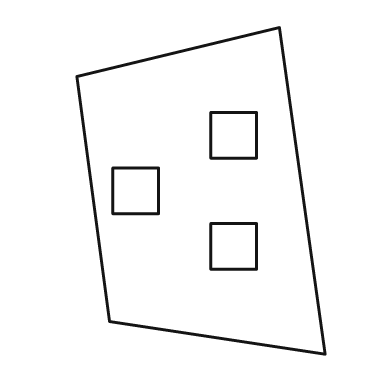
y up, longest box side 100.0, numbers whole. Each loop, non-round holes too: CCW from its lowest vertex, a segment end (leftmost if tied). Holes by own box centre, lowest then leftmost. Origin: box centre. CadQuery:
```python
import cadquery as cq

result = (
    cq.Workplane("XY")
    .moveTo(38.0, -50.0)
    .lineTo(24.0, 50.0)
    .lineTo(-38.0, 35.0)
    .lineTo(-28.0, -40.0)
    .close()
    .moveTo(3.0, -24.0)
    .lineTo(17.0, -24.0)
    .lineTo(17.0, -10.0)
    .lineTo(3.0, -10.0)
    .close()
    .moveTo(-27.0, -7.0)
    .lineTo(-13.0, -7.0)
    .lineTo(-13.0, 7.0)
    .lineTo(-27.0, 7.0)
    .close()
    .moveTo(3.0, 10.0)
    .lineTo(17.0, 10.0)
    .lineTo(17.0, 24.0)
    .lineTo(3.0, 24.0)
    .close()
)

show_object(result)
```